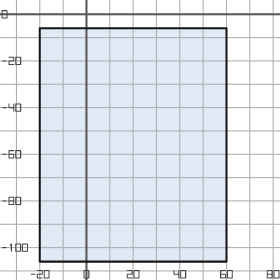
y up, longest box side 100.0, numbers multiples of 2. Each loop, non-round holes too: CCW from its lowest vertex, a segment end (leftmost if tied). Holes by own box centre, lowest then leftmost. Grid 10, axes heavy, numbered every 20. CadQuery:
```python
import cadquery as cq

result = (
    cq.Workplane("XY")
    .moveTo(-20.0, -106.0)
    .lineTo(60.0, -106.0)
    .lineTo(60.0, -6.0)
    .lineTo(-20.0, -6.0)
    .close()
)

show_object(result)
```